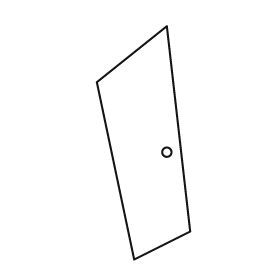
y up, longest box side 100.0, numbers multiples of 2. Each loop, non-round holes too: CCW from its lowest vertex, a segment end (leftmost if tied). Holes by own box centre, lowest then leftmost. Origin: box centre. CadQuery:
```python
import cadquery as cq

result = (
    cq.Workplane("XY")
    .moveTo(-4.0, -50.0)
    .lineTo(20.0, -38.0)
    .lineTo(10.0, 50.0)
    .lineTo(-20.0, 26.0)
    .close()
    .moveTo(10.0, -4.0)
    .circle(2.0)
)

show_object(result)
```